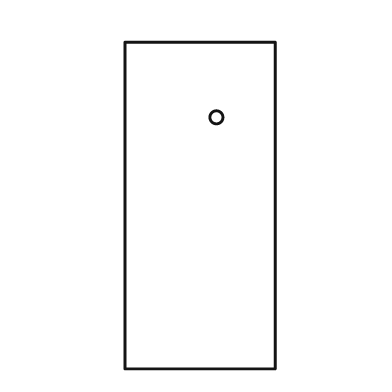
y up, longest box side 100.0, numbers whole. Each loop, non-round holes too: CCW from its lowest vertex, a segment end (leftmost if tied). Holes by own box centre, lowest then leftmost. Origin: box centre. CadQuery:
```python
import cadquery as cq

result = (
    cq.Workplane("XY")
    .moveTo(-23.0, -50.0)
    .lineTo(23.0, -50.0)
    .lineTo(23.0, 50.0)
    .lineTo(-23.0, 50.0)
    .close()
    .moveTo(5.0, 27.0)
    .circle(2.0)
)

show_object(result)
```